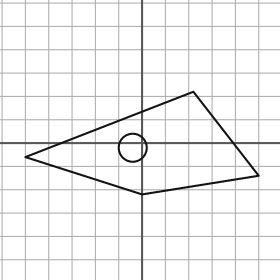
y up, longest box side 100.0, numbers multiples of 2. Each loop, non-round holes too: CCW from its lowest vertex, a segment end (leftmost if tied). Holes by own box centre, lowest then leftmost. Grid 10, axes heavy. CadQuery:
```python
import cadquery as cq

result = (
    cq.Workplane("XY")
    .moveTo(0.0, -22.0)
    .lineTo(50.0, -14.0)
    .lineTo(22.0, 22.0)
    .lineTo(-50.0, -6.0)
    .close()
    .moveTo(-4.0, -2.0)
    .circle(6.0)
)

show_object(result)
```